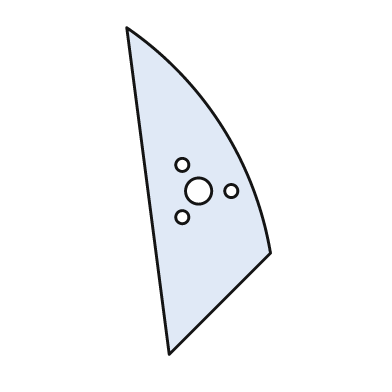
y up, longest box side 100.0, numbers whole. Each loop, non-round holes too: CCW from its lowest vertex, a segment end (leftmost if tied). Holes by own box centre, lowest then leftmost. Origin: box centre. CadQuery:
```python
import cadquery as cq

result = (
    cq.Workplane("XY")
    .moveTo(-9.0, -50.0)
    .lineTo(22.0, -19.0)
    .threePointArc((7.0, 20.0), (-22.0, 50.0))
    .close()
    .moveTo(-5.0, -8.0)
    .circle(2.0)
    .moveTo(0.0, 0.0)
    .circle(4.0)
    .moveTo(10.0, 0.0)
    .circle(2.0)
    .moveTo(-5.0, 8.0)
    .circle(2.0)
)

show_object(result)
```